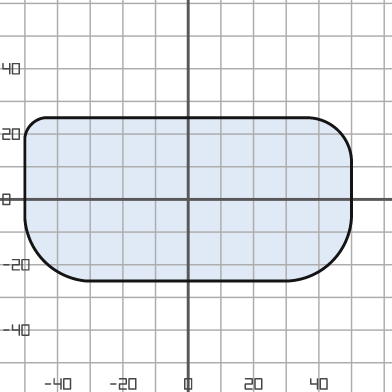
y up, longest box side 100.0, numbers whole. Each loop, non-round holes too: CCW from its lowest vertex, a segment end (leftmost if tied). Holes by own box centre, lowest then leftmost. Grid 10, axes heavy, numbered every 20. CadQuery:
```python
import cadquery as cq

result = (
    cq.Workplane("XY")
    .moveTo(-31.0, -25.0)
    .lineTo(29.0, -25.0)
    .threePointArc((44.0, -19.0), (50.0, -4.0))
    .lineTo(50.0, 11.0)
    .threePointArc((46.0, 21.0), (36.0, 25.0))
    .lineTo(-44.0, 25.0)
    .threePointArc((-48.0, 23.0), (-50.0, 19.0))
    .lineTo(-50.0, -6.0)
    .threePointArc((-44.0, -19.0), (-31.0, -25.0))
    .close()
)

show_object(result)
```